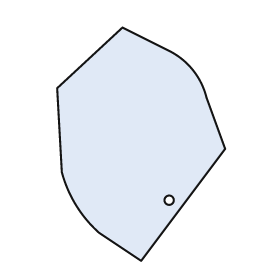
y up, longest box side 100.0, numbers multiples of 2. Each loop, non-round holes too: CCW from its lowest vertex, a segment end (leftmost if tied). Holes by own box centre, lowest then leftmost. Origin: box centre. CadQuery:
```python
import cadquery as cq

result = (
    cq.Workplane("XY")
    .moveTo(0.0, -50.0)
    .lineTo(36.0, -2.0)
    .lineTo(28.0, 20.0)
    .threePointArc((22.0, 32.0), (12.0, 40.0))
    .lineTo(-8.0, 50.0)
    .lineTo(-36.0, 24.0)
    .lineTo(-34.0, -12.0)
    .threePointArc((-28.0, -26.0), (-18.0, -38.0))
    .close()
    .moveTo(12.0, -24.0)
    .circle(2.0)
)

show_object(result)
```